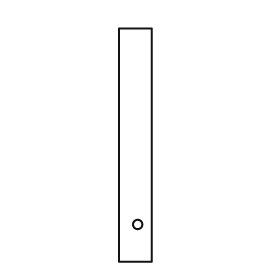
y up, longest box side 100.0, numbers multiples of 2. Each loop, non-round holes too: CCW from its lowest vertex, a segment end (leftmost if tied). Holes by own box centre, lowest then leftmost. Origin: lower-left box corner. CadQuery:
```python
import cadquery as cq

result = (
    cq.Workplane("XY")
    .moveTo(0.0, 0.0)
    .lineTo(14.0, 0.0)
    .lineTo(14.0, 100.0)
    .lineTo(0.0, 100.0)
    .close()
    .moveTo(8.0, 16.0)
    .circle(2.0)
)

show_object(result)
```